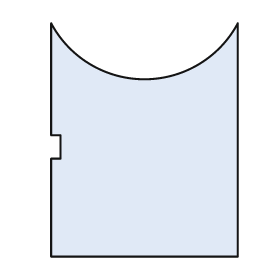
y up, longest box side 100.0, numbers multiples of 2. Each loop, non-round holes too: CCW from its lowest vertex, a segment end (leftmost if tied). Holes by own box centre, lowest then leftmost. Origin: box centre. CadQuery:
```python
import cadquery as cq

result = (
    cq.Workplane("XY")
    .moveTo(-40.0, -50.0)
    .lineTo(40.0, -50.0)
    .lineTo(40.0, 50.0)
    .threePointArc((0.0, 26.0), (-40.0, 50.0))
    .lineTo(-40.0, 2.0)
    .lineTo(-36.0, 2.0)
    .lineTo(-36.0, -8.0)
    .lineTo(-40.0, -8.0)
    .close()
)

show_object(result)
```